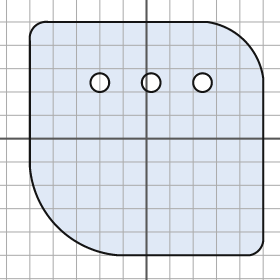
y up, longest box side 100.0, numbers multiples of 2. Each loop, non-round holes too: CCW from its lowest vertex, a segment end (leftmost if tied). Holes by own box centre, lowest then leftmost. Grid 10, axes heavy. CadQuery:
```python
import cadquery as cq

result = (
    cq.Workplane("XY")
    .moveTo(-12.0, -50.0)
    .lineTo(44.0, -50.0)
    .threePointArc((48.0, -48.0), (50.0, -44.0))
    .lineTo(50.0, 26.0)
    .threePointArc((42.0, 42.0), (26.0, 50.0))
    .lineTo(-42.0, 50.0)
    .threePointArc((-48.0, 48.0), (-50.0, 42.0))
    .lineTo(-50.0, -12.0)
    .threePointArc((-38.0, -38.0), (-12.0, -50.0))
    .close()
    .moveTo(-20.0, 24.0)
    .circle(4.0)
    .moveTo(2.0, 24.0)
    .circle(4.0)
    .moveTo(24.0, 24.0)
    .circle(4.0)
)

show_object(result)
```